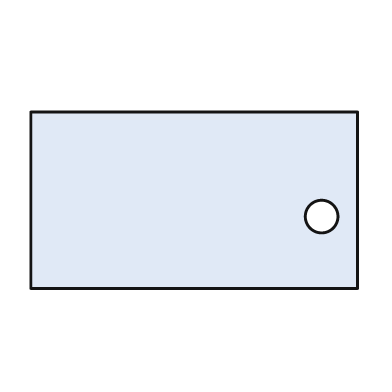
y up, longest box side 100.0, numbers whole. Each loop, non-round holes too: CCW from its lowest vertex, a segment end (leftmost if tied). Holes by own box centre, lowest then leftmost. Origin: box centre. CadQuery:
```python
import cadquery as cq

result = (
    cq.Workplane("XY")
    .moveTo(-50.0, -27.0)
    .lineTo(50.0, -27.0)
    .lineTo(50.0, 27.0)
    .lineTo(-50.0, 27.0)
    .close()
    .moveTo(39.0, -5.0)
    .circle(5.0)
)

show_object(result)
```